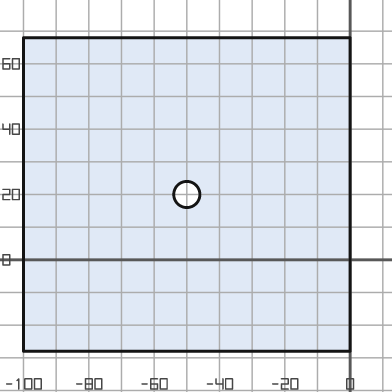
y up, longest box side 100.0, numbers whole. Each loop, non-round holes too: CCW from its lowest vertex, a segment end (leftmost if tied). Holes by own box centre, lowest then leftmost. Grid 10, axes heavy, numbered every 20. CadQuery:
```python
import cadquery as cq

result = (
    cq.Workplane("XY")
    .moveTo(-100.0, -28.0)
    .lineTo(0.0, -28.0)
    .lineTo(0.0, 68.0)
    .lineTo(-100.0, 68.0)
    .close()
    .moveTo(-50.0, 20.0)
    .circle(4.0)
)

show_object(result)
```